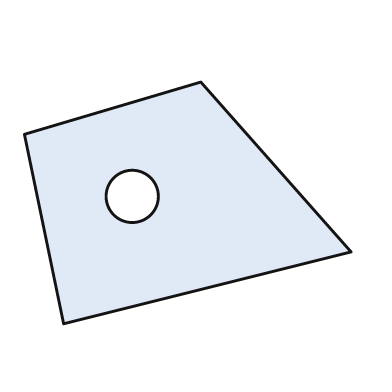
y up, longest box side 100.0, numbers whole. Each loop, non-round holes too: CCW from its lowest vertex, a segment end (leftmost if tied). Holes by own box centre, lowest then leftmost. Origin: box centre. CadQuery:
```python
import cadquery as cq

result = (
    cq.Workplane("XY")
    .moveTo(-38.0, -37.0)
    .lineTo(50.0, -15.0)
    .lineTo(4.0, 37.0)
    .lineTo(-50.0, 21.0)
    .close()
    .moveTo(-17.0, 2.0)
    .circle(8.0)
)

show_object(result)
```